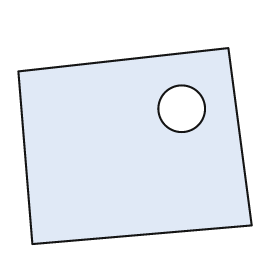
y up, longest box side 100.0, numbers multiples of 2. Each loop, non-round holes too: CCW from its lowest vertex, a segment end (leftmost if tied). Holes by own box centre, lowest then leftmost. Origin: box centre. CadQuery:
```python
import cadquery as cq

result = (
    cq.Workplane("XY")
    .moveTo(-44.0, -42.0)
    .lineTo(50.0, -34.0)
    .lineTo(40.0, 42.0)
    .lineTo(-50.0, 32.0)
    .close()
    .moveTo(20.0, 16.0)
    .circle(10.0)
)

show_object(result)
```